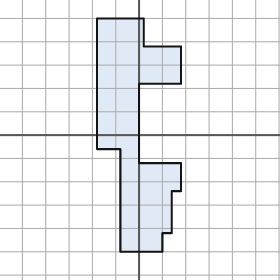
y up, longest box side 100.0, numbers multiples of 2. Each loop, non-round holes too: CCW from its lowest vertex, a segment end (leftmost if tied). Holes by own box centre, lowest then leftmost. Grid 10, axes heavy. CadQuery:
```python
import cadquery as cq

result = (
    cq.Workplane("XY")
    .moveTo(-8.0, -50.0)
    .lineTo(10.0, -50.0)
    .lineTo(10.0, -42.0)
    .lineTo(14.0, -42.0)
    .lineTo(14.0, -24.0)
    .lineTo(18.0, -24.0)
    .lineTo(18.0, -12.0)
    .lineTo(0.0, -12.0)
    .lineTo(0.0, 22.0)
    .lineTo(18.0, 22.0)
    .lineTo(18.0, 38.0)
    .lineTo(2.0, 38.0)
    .lineTo(2.0, 50.0)
    .lineTo(-18.0, 50.0)
    .lineTo(-18.0, -6.0)
    .lineTo(-8.0, -6.0)
    .close()
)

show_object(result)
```